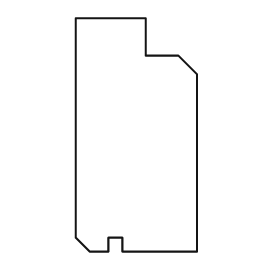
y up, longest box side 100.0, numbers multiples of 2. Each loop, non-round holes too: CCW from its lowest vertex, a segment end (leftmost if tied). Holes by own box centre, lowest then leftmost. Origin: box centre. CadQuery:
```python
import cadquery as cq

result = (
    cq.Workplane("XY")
    .moveTo(-20.0, -50.0)
    .lineTo(-12.0, -50.0)
    .lineTo(-12.0, -44.0)
    .lineTo(-6.0, -44.0)
    .lineTo(-6.0, -50.0)
    .lineTo(26.0, -50.0)
    .lineTo(26.0, 26.0)
    .lineTo(18.0, 34.0)
    .lineTo(4.0, 34.0)
    .lineTo(4.0, 50.0)
    .lineTo(-26.0, 50.0)
    .lineTo(-26.0, -44.0)
    .close()
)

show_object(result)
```